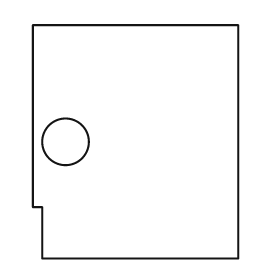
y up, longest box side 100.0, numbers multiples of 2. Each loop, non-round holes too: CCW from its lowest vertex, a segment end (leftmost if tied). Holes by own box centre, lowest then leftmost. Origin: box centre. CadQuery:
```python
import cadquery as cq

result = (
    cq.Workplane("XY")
    .moveTo(-40.0, -50.0)
    .lineTo(44.0, -50.0)
    .lineTo(44.0, 50.0)
    .lineTo(-44.0, 50.0)
    .lineTo(-44.0, -28.0)
    .lineTo(-40.0, -28.0)
    .close()
    .moveTo(-30.0, 0.0)
    .circle(10.0)
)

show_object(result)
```